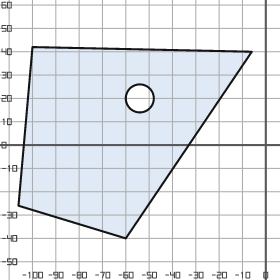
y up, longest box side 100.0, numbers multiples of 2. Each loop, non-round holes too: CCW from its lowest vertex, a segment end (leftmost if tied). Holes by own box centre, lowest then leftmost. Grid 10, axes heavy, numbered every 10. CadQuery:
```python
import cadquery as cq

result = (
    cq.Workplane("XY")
    .moveTo(-60.0, -40.0)
    .lineTo(-6.0, 40.0)
    .lineTo(-100.0, 42.0)
    .lineTo(-106.0, -26.0)
    .close()
    .moveTo(-54.0, 20.0)
    .circle(6.0)
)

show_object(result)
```